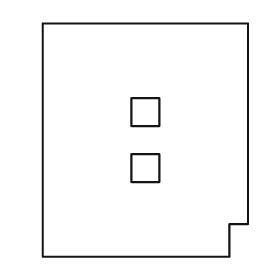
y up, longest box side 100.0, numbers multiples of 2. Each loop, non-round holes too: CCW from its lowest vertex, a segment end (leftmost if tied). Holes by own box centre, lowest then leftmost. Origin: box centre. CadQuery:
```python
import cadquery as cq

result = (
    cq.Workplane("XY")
    .moveTo(-44.0, -50.0)
    .lineTo(36.0, -50.0)
    .lineTo(36.0, -36.0)
    .lineTo(44.0, -36.0)
    .lineTo(44.0, 50.0)
    .lineTo(-44.0, 50.0)
    .close()
    .moveTo(-6.0, -18.0)
    .lineTo(6.0, -18.0)
    .lineTo(6.0, -6.0)
    .lineTo(-6.0, -6.0)
    .close()
    .moveTo(-6.0, 6.0)
    .lineTo(6.0, 6.0)
    .lineTo(6.0, 18.0)
    .lineTo(-6.0, 18.0)
    .close()
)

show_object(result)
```